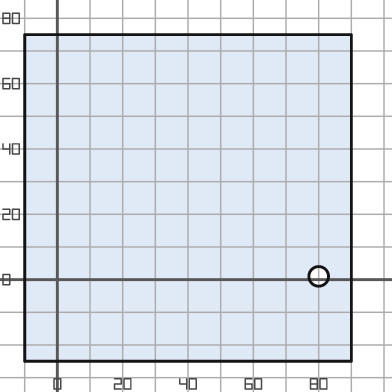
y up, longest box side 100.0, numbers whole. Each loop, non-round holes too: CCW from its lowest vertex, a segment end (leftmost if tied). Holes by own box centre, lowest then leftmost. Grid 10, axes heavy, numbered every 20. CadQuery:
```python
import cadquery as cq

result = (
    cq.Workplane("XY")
    .moveTo(-10.0, -25.0)
    .lineTo(90.0, -25.0)
    .lineTo(90.0, 75.0)
    .lineTo(-10.0, 75.0)
    .close()
    .moveTo(80.0, 1.0)
    .circle(3.0)
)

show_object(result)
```